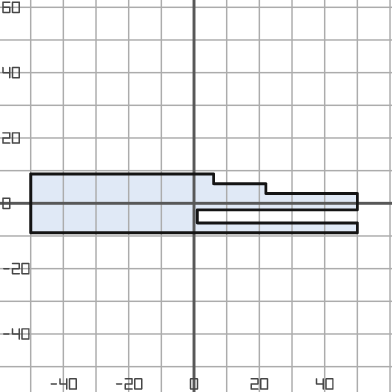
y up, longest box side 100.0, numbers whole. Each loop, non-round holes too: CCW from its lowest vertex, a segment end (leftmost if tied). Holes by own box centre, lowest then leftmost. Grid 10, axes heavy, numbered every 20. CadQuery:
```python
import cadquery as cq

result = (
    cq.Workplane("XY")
    .moveTo(-50.0, -9.0)
    .lineTo(50.0, -9.0)
    .lineTo(50.0, -6.0)
    .lineTo(1.0, -6.0)
    .lineTo(1.0, -2.0)
    .lineTo(50.0, -2.0)
    .lineTo(50.0, 3.0)
    .lineTo(22.0, 3.0)
    .lineTo(22.0, 6.0)
    .lineTo(6.0, 6.0)
    .lineTo(6.0, 9.0)
    .lineTo(-50.0, 9.0)
    .close()
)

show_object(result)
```